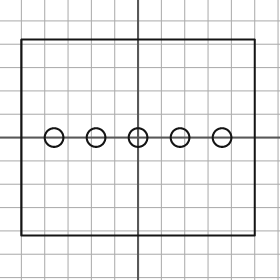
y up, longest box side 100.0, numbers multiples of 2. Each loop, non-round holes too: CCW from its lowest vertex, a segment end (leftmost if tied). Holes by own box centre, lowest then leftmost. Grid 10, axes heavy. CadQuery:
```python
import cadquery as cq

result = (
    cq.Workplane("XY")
    .moveTo(-50.0, -42.0)
    .lineTo(50.0, -42.0)
    .lineTo(50.0, 42.0)
    .lineTo(-50.0, 42.0)
    .close()
    .moveTo(-36.0, 0.0)
    .circle(4.0)
    .moveTo(-18.0, 0.0)
    .circle(4.0)
    .moveTo(0.0, 0.0)
    .circle(4.0)
    .moveTo(18.0, 0.0)
    .circle(4.0)
    .moveTo(36.0, 0.0)
    .circle(4.0)
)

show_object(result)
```